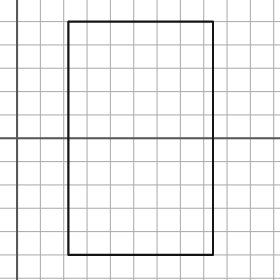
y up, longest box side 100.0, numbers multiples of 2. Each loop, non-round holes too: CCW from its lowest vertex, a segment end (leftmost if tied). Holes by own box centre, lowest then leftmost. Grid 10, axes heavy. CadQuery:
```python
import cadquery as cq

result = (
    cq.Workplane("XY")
    .moveTo(22.0, -50.0)
    .lineTo(84.0, -50.0)
    .lineTo(84.0, 50.0)
    .lineTo(22.0, 50.0)
    .close()
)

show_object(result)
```